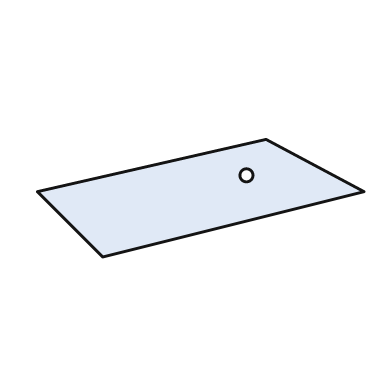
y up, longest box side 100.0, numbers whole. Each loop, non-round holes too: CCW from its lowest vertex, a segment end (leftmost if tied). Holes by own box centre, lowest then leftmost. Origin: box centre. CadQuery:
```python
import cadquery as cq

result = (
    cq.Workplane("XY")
    .moveTo(-30.0, -18.0)
    .lineTo(50.0, 2.0)
    .lineTo(20.0, 18.0)
    .lineTo(-50.0, 2.0)
    .close()
    .moveTo(14.0, 7.0)
    .circle(2.0)
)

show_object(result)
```